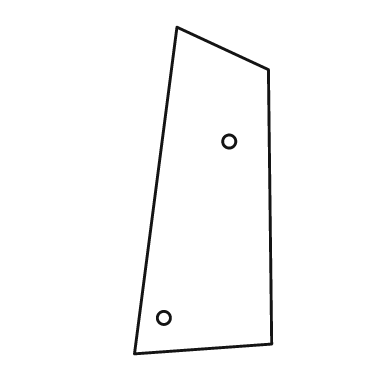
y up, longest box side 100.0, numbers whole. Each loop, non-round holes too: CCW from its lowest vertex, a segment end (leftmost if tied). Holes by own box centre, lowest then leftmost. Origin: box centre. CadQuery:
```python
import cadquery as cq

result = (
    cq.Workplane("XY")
    .moveTo(-21.0, -50.0)
    .lineTo(21.0, -47.0)
    .lineTo(20.0, 37.0)
    .lineTo(-8.0, 50.0)
    .close()
    .moveTo(-12.0, -39.0)
    .circle(2.0)
    .moveTo(8.0, 15.0)
    .circle(2.0)
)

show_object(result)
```